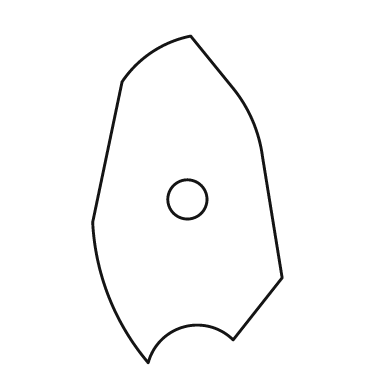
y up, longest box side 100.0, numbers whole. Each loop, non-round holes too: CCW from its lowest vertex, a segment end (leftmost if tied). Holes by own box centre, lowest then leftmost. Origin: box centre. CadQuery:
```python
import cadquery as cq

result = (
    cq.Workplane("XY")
    .moveTo(-12.0, -50.0)
    .threePointArc((-1.0, -39.0), (14.0, -43.0))
    .lineTo(29.0, -24.0)
    .lineTo(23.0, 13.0)
    .threePointArc((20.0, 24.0), (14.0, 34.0))
    .lineTo(1.0, 50.0)
    .threePointArc((-11.0, 45.0), (-20.0, 36.0))
    .lineTo(-29.0, -7.0)
    .threePointArc((-24.0, -30.0), (-12.0, -50.0))
    .close()
    .moveTo(0.0, 0.0)
    .circle(6.0)
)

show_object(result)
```